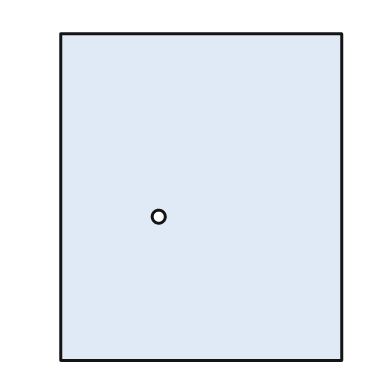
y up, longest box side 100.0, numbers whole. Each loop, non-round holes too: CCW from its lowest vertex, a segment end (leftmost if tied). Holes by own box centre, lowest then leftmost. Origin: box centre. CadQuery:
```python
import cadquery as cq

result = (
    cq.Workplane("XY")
    .moveTo(-43.0, -50.0)
    .lineTo(43.0, -50.0)
    .lineTo(43.0, 50.0)
    .lineTo(-43.0, 50.0)
    .close()
    .moveTo(-13.0, -6.0)
    .circle(2.0)
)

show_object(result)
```